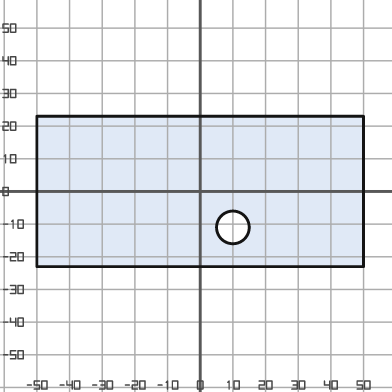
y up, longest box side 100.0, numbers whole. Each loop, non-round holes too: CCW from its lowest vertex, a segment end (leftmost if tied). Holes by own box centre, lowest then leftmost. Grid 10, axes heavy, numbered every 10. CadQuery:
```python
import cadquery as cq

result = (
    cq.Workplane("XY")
    .moveTo(-50.0, -23.0)
    .lineTo(50.0, -23.0)
    .lineTo(50.0, 23.0)
    .lineTo(-50.0, 23.0)
    .close()
    .moveTo(10.0, -11.0)
    .circle(5.0)
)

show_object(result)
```